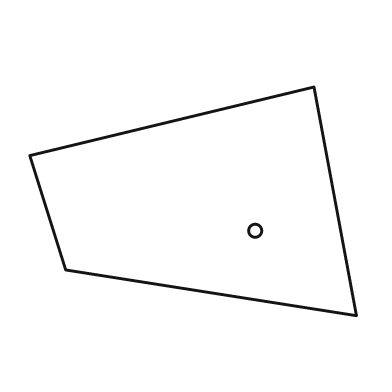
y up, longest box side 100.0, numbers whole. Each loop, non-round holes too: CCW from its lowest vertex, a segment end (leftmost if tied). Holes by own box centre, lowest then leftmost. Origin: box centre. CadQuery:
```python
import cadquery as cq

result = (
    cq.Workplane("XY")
    .moveTo(50.0, -35.0)
    .lineTo(37.0, 35.0)
    .lineTo(-50.0, 14.0)
    .lineTo(-39.0, -21.0)
    .close()
    .moveTo(19.0, -9.0)
    .circle(2.0)
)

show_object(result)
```